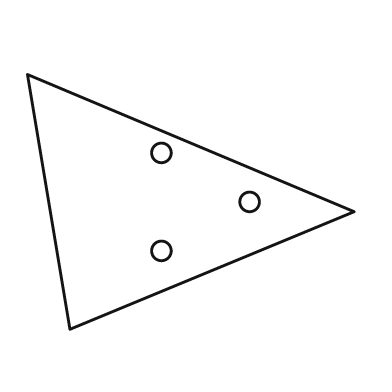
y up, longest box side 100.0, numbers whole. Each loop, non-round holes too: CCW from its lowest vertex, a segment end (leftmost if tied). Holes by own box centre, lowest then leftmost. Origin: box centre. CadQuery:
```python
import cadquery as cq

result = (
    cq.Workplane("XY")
    .moveTo(-37.0, -39.0)
    .lineTo(50.0, -3.0)
    .lineTo(-50.0, 39.0)
    .close()
    .moveTo(-9.0, -15.0)
    .circle(3.0)
    .moveTo(18.0, 0.0)
    .circle(3.0)
    .moveTo(-9.0, 15.0)
    .circle(3.0)
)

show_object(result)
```